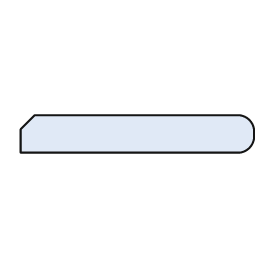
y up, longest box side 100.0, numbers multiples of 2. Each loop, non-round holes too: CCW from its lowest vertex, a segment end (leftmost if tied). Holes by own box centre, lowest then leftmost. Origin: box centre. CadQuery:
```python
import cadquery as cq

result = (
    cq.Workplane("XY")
    .moveTo(-50.0, -8.0)
    .lineTo(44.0, -8.0)
    .threePointArc((48.0, -6.0), (50.0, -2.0))
    .lineTo(50.0, 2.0)
    .threePointArc((48.0, 6.0), (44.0, 8.0))
    .lineTo(-44.0, 8.0)
    .lineTo(-50.0, 2.0)
    .close()
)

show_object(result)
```